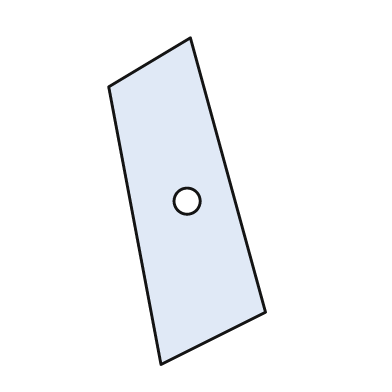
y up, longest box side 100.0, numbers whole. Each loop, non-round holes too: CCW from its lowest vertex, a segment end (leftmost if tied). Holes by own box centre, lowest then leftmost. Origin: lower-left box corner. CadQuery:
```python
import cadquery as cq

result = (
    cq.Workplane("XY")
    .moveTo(16.0, 0.0)
    .lineTo(48.0, 16.0)
    .lineTo(25.0, 100.0)
    .lineTo(0.0, 85.0)
    .close()
    .moveTo(24.0, 50.0)
    .circle(4.0)
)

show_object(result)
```